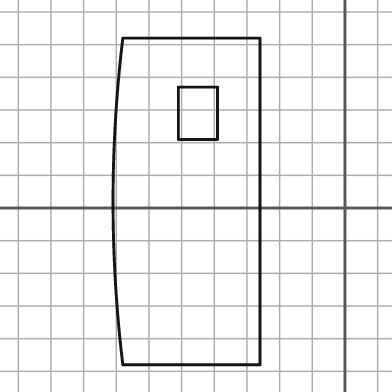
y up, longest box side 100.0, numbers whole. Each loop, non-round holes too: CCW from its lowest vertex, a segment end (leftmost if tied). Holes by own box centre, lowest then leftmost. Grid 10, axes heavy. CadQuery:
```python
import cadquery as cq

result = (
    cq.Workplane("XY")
    .moveTo(-68.0, -48.0)
    .lineTo(-26.0, -48.0)
    .lineTo(-26.0, 52.0)
    .lineTo(-68.0, 52.0)
    .threePointArc((-71.0, 2.0), (-68.0, -48.0))
    .close()
    .moveTo(-51.0, 21.0)
    .lineTo(-39.0, 21.0)
    .lineTo(-39.0, 37.0)
    .lineTo(-51.0, 37.0)
    .close()
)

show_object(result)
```